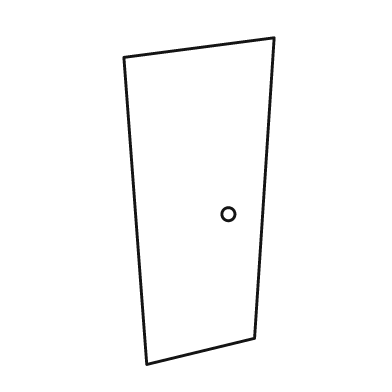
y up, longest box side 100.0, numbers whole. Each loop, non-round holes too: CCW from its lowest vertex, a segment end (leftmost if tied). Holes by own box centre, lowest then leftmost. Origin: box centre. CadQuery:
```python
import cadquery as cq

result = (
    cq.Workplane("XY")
    .moveTo(-16.0, -50.0)
    .lineTo(17.0, -42.0)
    .lineTo(23.0, 50.0)
    .lineTo(-23.0, 44.0)
    .close()
    .moveTo(9.0, -4.0)
    .circle(2.0)
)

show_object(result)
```